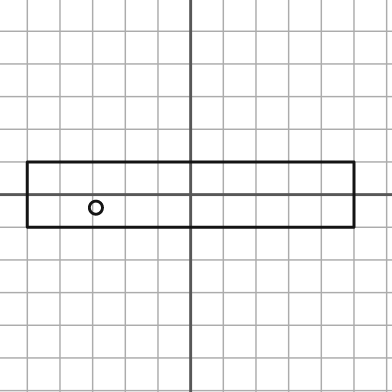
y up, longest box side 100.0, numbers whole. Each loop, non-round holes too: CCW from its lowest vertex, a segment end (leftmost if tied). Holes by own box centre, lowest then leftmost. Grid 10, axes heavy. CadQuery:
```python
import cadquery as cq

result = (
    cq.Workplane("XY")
    .moveTo(-50.0, -10.0)
    .lineTo(50.0, -10.0)
    .lineTo(50.0, 10.0)
    .lineTo(-50.0, 10.0)
    .close()
    .moveTo(-29.0, -4.0)
    .circle(2.0)
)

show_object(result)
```